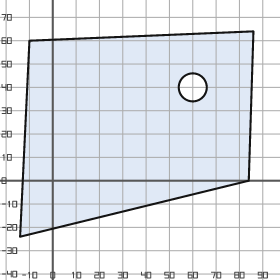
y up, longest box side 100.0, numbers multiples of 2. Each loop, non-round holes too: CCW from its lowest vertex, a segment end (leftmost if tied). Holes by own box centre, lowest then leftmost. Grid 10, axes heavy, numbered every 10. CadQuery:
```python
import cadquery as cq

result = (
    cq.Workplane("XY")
    .moveTo(-14.0, -24.0)
    .lineTo(84.0, 0.0)
    .lineTo(86.0, 64.0)
    .lineTo(-10.0, 60.0)
    .close()
    .moveTo(60.0, 40.0)
    .circle(6.0)
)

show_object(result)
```